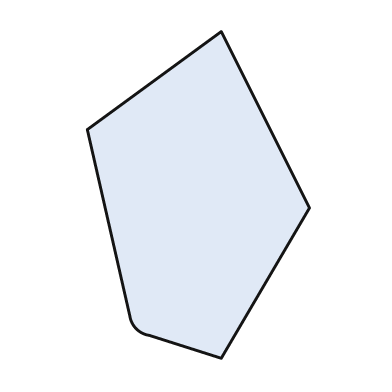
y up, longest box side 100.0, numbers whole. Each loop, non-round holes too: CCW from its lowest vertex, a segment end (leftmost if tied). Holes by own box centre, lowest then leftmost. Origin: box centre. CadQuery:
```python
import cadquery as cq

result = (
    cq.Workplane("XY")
    .moveTo(7.0, -50.0)
    .lineTo(34.0, -4.0)
    .lineTo(7.0, 50.0)
    .lineTo(-34.0, 20.0)
    .lineTo(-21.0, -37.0)
    .threePointArc((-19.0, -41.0), (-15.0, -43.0))
    .close()
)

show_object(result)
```